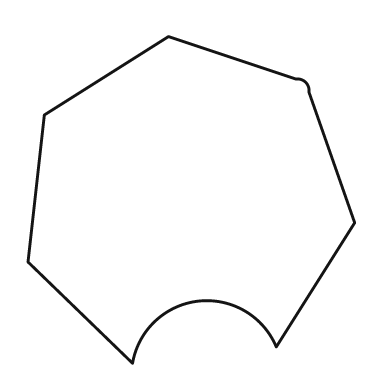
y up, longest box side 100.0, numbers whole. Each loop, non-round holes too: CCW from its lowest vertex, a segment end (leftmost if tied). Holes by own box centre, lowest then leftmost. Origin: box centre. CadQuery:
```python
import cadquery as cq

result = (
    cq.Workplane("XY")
    .moveTo(-18.0, -50.0)
    .threePointArc((2.0, -31.0), (26.0, -45.0))
    .lineTo(50.0, -7.0)
    .lineTo(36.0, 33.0)
    .threePointArc((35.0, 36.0), (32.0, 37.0))
    .lineTo(-7.0, 50.0)
    .lineTo(-45.0, 26.0)
    .lineTo(-50.0, -19.0)
    .close()
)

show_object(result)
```